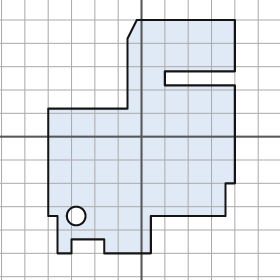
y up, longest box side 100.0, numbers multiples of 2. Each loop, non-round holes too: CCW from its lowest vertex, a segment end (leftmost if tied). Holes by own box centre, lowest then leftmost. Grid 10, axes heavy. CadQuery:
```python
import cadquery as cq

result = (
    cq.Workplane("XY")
    .moveTo(-36.0, -50.0)
    .lineTo(-30.0, -50.0)
    .lineTo(-30.0, -44.0)
    .lineTo(-16.0, -44.0)
    .lineTo(-16.0, -50.0)
    .lineTo(4.0, -50.0)
    .lineTo(4.0, -34.0)
    .lineTo(36.0, -34.0)
    .lineTo(36.0, -20.0)
    .lineTo(40.0, -20.0)
    .lineTo(40.0, 22.0)
    .lineTo(10.0, 22.0)
    .lineTo(10.0, 28.0)
    .lineTo(40.0, 28.0)
    .lineTo(40.0, 50.0)
    .lineTo(-2.0, 50.0)
    .lineTo(-6.0, 42.0)
    .lineTo(-6.0, 12.0)
    .lineTo(-40.0, 12.0)
    .lineTo(-40.0, -34.0)
    .lineTo(-36.0, -34.0)
    .close()
    .moveTo(-28.0, -34.0)
    .circle(4.0)
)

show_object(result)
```